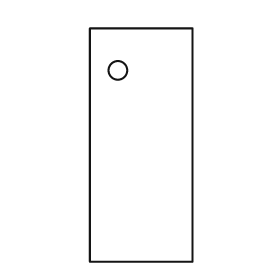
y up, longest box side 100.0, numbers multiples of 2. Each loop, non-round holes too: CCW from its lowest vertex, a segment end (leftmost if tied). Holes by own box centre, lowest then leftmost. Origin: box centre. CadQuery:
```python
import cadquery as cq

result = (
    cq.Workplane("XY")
    .moveTo(-22.0, -50.0)
    .lineTo(22.0, -50.0)
    .lineTo(22.0, 50.0)
    .lineTo(-22.0, 50.0)
    .close()
    .moveTo(-10.0, 32.0)
    .circle(4.0)
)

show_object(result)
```